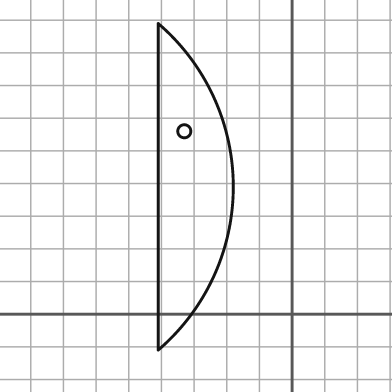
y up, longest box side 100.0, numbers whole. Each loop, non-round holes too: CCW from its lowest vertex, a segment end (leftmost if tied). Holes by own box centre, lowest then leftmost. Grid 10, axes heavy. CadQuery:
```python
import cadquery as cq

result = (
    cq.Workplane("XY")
    .moveTo(-41.0, -11.0)
    .threePointArc((-18.0, 39.0), (-41.0, 89.0))
    .close()
    .moveTo(-33.0, 56.0)
    .circle(2.0)
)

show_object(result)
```